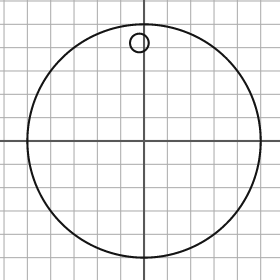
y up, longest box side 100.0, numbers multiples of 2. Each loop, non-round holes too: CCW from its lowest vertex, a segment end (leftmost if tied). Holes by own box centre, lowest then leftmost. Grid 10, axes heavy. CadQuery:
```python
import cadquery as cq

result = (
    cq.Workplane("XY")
    .moveTo(0.0, 0.0)
    .circle(50.0)
    .moveTo(-2.0, 42.0)
    .circle(4.0)
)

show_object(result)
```